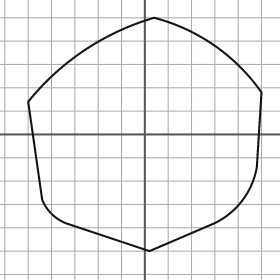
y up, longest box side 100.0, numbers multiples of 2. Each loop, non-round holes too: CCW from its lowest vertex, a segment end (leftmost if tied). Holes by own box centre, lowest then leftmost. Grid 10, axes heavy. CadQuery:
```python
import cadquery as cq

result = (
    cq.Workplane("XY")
    .moveTo(2.0, -50.0)
    .lineTo(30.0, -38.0)
    .threePointArc((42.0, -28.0), (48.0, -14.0))
    .lineTo(50.0, 18.0)
    .threePointArc((30.0, 38.0), (4.0, 50.0))
    .threePointArc((-26.0, 36.0), (-50.0, 14.0))
    .lineTo(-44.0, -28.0)
    .threePointArc((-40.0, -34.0), (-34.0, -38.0))
    .close()
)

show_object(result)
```